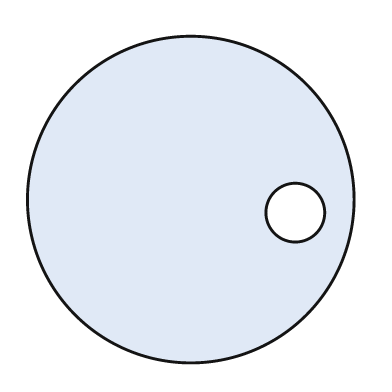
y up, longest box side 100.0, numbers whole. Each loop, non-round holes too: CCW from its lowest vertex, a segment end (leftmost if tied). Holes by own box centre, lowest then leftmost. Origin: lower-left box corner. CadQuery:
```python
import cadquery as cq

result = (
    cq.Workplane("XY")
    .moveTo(50.0, 50.0)
    .circle(50.0)
    .moveTo(82.0, 46.0)
    .circle(9.0)
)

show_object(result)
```